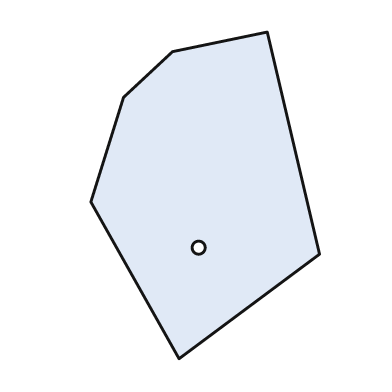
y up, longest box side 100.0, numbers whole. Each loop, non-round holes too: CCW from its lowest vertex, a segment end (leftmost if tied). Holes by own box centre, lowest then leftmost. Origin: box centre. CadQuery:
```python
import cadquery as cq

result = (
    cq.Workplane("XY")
    .moveTo(-8.0, -50.0)
    .lineTo(35.0, -18.0)
    .lineTo(19.0, 50.0)
    .lineTo(-10.0, 44.0)
    .lineTo(-25.0, 30.0)
    .lineTo(-35.0, -2.0)
    .close()
    .moveTo(-2.0, -16.0)
    .circle(2.0)
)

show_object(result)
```